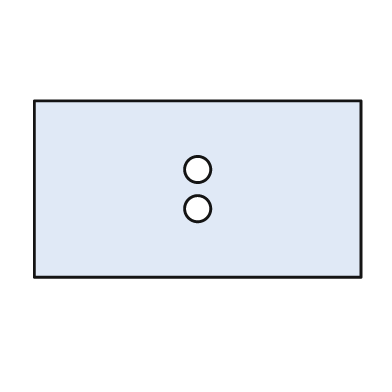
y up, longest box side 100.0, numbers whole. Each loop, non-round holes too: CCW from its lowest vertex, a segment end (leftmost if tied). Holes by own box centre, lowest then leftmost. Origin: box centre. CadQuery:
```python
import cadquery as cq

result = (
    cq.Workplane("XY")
    .moveTo(-50.0, -27.0)
    .lineTo(50.0, -27.0)
    .lineTo(50.0, 27.0)
    .lineTo(-50.0, 27.0)
    .close()
    .moveTo(0.0, -6.0)
    .circle(4.0)
    .moveTo(0.0, 6.0)
    .circle(4.0)
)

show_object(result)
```